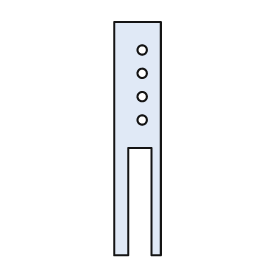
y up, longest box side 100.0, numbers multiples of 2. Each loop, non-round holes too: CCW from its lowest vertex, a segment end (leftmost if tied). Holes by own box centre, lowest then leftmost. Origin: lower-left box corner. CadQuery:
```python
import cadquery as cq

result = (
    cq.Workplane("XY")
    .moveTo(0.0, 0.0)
    .lineTo(6.0, 0.0)
    .lineTo(6.0, 46.0)
    .lineTo(16.0, 46.0)
    .lineTo(16.0, 0.0)
    .lineTo(20.0, 0.0)
    .lineTo(20.0, 100.0)
    .lineTo(0.0, 100.0)
    .close()
    .moveTo(12.0, 58.0)
    .circle(2.0)
    .moveTo(12.0, 68.0)
    .circle(2.0)
    .moveTo(12.0, 78.0)
    .circle(2.0)
    .moveTo(12.0, 88.0)
    .circle(2.0)
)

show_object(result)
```